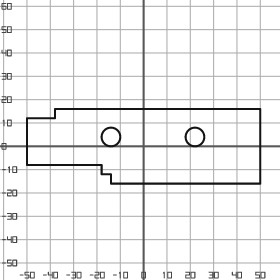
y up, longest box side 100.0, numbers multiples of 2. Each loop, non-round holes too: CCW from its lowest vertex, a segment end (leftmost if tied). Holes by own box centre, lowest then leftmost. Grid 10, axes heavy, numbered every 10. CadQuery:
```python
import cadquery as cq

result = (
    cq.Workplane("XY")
    .moveTo(-14.0, -16.0)
    .lineTo(50.0, -16.0)
    .lineTo(50.0, 16.0)
    .lineTo(-38.0, 16.0)
    .lineTo(-38.0, 12.0)
    .lineTo(-50.0, 12.0)
    .lineTo(-50.0, -8.0)
    .lineTo(-18.0, -8.0)
    .lineTo(-18.0, -12.0)
    .lineTo(-14.0, -12.0)
    .close()
    .moveTo(-14.0, 4.0)
    .circle(4.0)
    .moveTo(22.0, 4.0)
    .circle(4.0)
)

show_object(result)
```